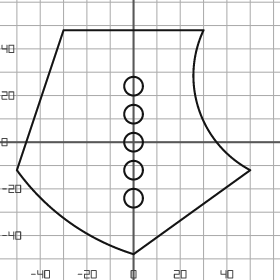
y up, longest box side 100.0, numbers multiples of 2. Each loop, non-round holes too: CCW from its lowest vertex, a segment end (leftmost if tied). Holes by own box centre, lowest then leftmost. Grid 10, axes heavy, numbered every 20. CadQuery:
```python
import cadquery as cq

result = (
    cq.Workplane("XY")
    .moveTo(0.0, -48.0)
    .lineTo(50.0, -12.0)
    .threePointArc((28.0, 14.0), (30.0, 48.0))
    .lineTo(-30.0, 48.0)
    .lineTo(-50.0, -12.0)
    .threePointArc((-28.0, -34.0), (0.0, -48.0))
    .close()
    .moveTo(0.0, -24.0)
    .circle(4.0)
    .moveTo(0.0, -12.0)
    .circle(4.0)
    .moveTo(0.0, 0.0)
    .circle(4.0)
    .moveTo(0.0, 12.0)
    .circle(4.0)
    .moveTo(0.0, 24.0)
    .circle(4.0)
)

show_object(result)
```